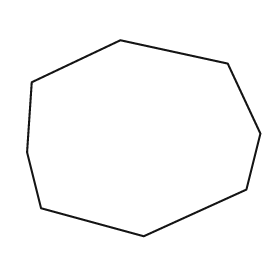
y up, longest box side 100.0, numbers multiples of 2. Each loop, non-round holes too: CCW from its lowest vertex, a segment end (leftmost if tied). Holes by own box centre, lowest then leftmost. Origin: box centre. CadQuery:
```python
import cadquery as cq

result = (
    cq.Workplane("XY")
    .moveTo(0.0, -42.0)
    .lineTo(44.0, -22.0)
    .lineTo(50.0, 2.0)
    .lineTo(36.0, 32.0)
    .lineTo(-10.0, 42.0)
    .lineTo(-48.0, 24.0)
    .lineTo(-50.0, -6.0)
    .lineTo(-44.0, -30.0)
    .close()
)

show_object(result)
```